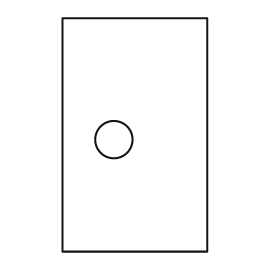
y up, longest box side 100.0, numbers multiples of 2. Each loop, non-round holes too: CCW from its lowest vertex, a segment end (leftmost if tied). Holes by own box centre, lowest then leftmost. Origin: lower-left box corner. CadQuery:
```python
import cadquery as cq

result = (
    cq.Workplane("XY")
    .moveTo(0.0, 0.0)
    .lineTo(62.0, 0.0)
    .lineTo(62.0, 100.0)
    .lineTo(0.0, 100.0)
    .close()
    .moveTo(22.0, 48.0)
    .circle(8.0)
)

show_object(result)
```